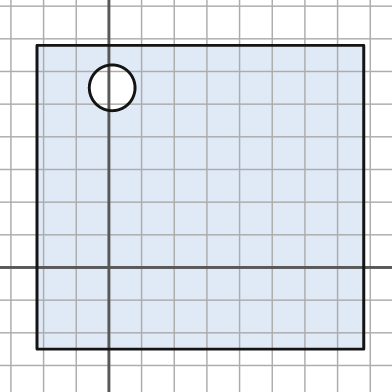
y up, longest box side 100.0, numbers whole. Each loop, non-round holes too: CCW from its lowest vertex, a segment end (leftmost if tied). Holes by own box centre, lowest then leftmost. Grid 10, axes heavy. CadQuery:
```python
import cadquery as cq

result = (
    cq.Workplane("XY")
    .moveTo(-22.0, -25.0)
    .lineTo(78.0, -25.0)
    .lineTo(78.0, 68.0)
    .lineTo(-22.0, 68.0)
    .close()
    .moveTo(1.0, 55.0)
    .circle(7.0)
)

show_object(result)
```